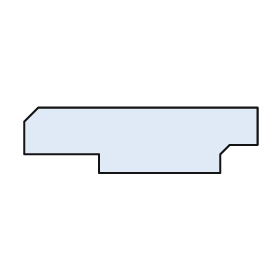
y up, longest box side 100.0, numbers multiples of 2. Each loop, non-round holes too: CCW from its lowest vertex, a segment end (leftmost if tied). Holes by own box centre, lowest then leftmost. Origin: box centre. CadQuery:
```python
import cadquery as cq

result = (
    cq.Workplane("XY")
    .moveTo(-18.0, -14.0)
    .lineTo(34.0, -14.0)
    .lineTo(34.0, -6.0)
    .lineTo(38.0, -2.0)
    .lineTo(50.0, -2.0)
    .lineTo(50.0, 14.0)
    .lineTo(-44.0, 14.0)
    .lineTo(-50.0, 8.0)
    .lineTo(-50.0, -6.0)
    .lineTo(-18.0, -6.0)
    .close()
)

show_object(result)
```